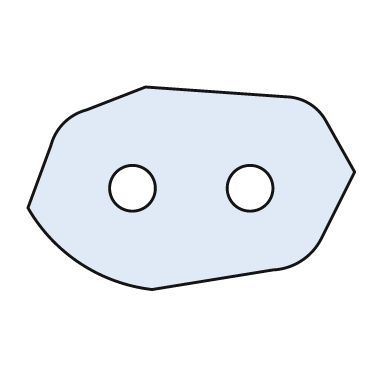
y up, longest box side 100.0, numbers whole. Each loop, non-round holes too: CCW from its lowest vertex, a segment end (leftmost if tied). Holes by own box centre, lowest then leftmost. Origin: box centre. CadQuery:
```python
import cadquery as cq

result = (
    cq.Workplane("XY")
    .moveTo(-12.0, -31.0)
    .lineTo(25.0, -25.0)
    .threePointArc((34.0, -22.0), (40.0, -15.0))
    .lineTo(50.0, 5.0)
    .lineTo(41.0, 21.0)
    .threePointArc((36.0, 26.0), (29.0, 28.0))
    .lineTo(-14.0, 31.0)
    .lineTo(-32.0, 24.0)
    .threePointArc((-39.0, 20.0), (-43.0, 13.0))
    .lineTo(-50.0, -6.0)
    .threePointArc((-34.0, -23.0), (-12.0, -31.0))
    .close()
    .moveTo(-18.0, 0.0)
    .circle(7.0)
    .moveTo(18.0, 0.0)
    .circle(7.0)
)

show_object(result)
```